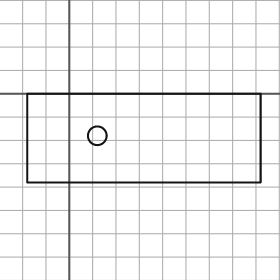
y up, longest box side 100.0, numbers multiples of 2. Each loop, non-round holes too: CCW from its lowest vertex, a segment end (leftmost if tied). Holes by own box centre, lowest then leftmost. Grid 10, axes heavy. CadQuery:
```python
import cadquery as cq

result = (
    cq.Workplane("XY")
    .moveTo(-18.0, -38.0)
    .lineTo(82.0, -38.0)
    .lineTo(82.0, 0.0)
    .lineTo(-18.0, 0.0)
    .close()
    .moveTo(12.0, -18.0)
    .circle(4.0)
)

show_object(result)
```